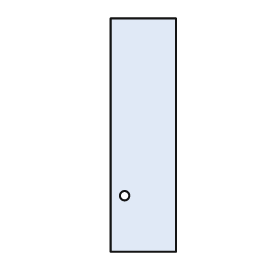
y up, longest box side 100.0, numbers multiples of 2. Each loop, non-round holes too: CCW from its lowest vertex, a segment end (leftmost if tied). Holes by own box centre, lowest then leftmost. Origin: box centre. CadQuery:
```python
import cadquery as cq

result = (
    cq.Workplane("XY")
    .moveTo(-14.0, -50.0)
    .lineTo(14.0, -50.0)
    .lineTo(14.0, 50.0)
    .lineTo(-14.0, 50.0)
    .close()
    .moveTo(-8.0, -26.0)
    .circle(2.0)
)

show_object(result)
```